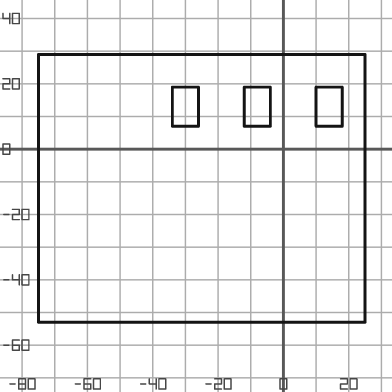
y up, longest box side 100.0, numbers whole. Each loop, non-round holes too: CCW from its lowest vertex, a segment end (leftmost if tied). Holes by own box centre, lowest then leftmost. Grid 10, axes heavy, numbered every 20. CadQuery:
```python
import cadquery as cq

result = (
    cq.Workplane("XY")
    .moveTo(-75.0, -53.0)
    .lineTo(25.0, -53.0)
    .lineTo(25.0, 29.0)
    .lineTo(-75.0, 29.0)
    .close()
    .moveTo(-34.0, 7.0)
    .lineTo(-26.0, 7.0)
    .lineTo(-26.0, 19.0)
    .lineTo(-34.0, 19.0)
    .close()
    .moveTo(-12.0, 7.0)
    .lineTo(-4.0, 7.0)
    .lineTo(-4.0, 19.0)
    .lineTo(-12.0, 19.0)
    .close()
    .moveTo(10.0, 7.0)
    .lineTo(18.0, 7.0)
    .lineTo(18.0, 19.0)
    .lineTo(10.0, 19.0)
    .close()
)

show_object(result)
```